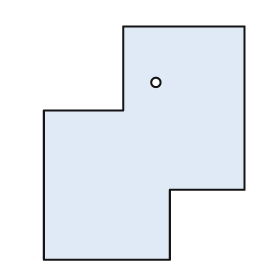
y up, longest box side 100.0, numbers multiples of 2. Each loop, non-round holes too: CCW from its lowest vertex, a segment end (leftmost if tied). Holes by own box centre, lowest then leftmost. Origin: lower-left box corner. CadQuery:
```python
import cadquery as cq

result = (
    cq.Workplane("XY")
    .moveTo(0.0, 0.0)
    .lineTo(54.0, 0.0)
    .lineTo(54.0, 30.0)
    .lineTo(86.0, 30.0)
    .lineTo(86.0, 100.0)
    .lineTo(34.0, 100.0)
    .lineTo(34.0, 64.0)
    .lineTo(0.0, 64.0)
    .close()
    .moveTo(48.0, 76.0)
    .circle(2.0)
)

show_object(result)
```